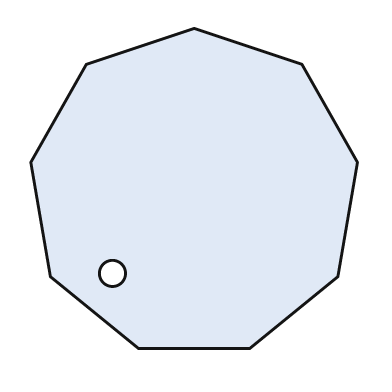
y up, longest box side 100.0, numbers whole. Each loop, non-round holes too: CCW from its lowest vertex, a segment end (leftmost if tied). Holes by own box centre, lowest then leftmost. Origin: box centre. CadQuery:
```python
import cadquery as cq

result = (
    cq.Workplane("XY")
    .moveTo(-17.0, -49.0)
    .lineTo(17.0, -49.0)
    .lineTo(44.0, -27.0)
    .lineTo(50.0, 8.0)
    .lineTo(33.0, 38.0)
    .lineTo(0.0, 49.0)
    .lineTo(-33.0, 38.0)
    .lineTo(-50.0, 8.0)
    .lineTo(-44.0, -27.0)
    .close()
    .moveTo(-25.0, -26.0)
    .circle(4.0)
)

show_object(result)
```